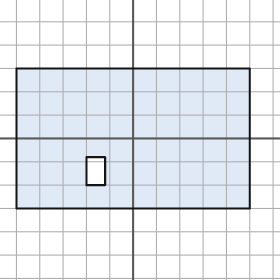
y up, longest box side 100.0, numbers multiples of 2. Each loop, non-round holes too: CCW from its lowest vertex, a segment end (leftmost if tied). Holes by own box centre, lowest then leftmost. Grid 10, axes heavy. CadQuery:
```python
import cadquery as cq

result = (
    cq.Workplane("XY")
    .moveTo(-50.0, -30.0)
    .lineTo(50.0, -30.0)
    .lineTo(50.0, 30.0)
    .lineTo(-50.0, 30.0)
    .close()
    .moveTo(-20.0, -20.0)
    .lineTo(-12.0, -20.0)
    .lineTo(-12.0, -8.0)
    .lineTo(-20.0, -8.0)
    .close()
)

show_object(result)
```